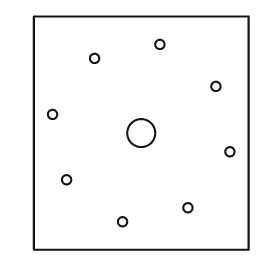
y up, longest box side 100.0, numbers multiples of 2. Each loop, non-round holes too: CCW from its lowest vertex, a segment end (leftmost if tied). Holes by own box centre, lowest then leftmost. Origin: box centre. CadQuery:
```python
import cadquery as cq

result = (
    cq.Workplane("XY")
    .moveTo(-46.0, -50.0)
    .lineTo(46.0, -50.0)
    .lineTo(46.0, 50.0)
    .lineTo(-46.0, 50.0)
    .close()
    .moveTo(-8.0, -38.0)
    .circle(2.0)
    .moveTo(20.0, -32.0)
    .circle(2.0)
    .moveTo(-32.0, -20.0)
    .circle(2.0)
    .moveTo(38.0, -8.0)
    .circle(2.0)
    .moveTo(0.0, 0.0)
    .circle(6.0)
    .moveTo(-38.0, 8.0)
    .circle(2.0)
    .moveTo(32.0, 20.0)
    .circle(2.0)
    .moveTo(-20.0, 32.0)
    .circle(2.0)
    .moveTo(8.0, 38.0)
    .circle(2.0)
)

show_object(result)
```